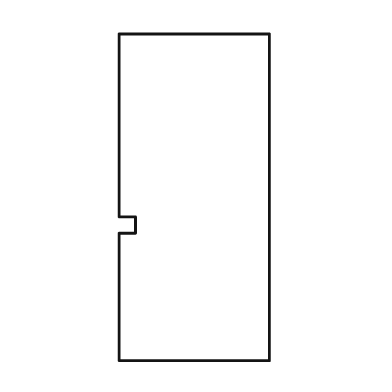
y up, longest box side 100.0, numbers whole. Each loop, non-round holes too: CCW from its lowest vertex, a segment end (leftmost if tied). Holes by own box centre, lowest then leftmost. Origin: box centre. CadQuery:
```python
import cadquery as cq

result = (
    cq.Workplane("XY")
    .moveTo(-23.0, -50.0)
    .lineTo(23.0, -50.0)
    .lineTo(23.0, 50.0)
    .lineTo(-23.0, 50.0)
    .lineTo(-23.0, -6.0)
    .lineTo(-18.0, -6.0)
    .lineTo(-18.0, -11.0)
    .lineTo(-23.0, -11.0)
    .close()
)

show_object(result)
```